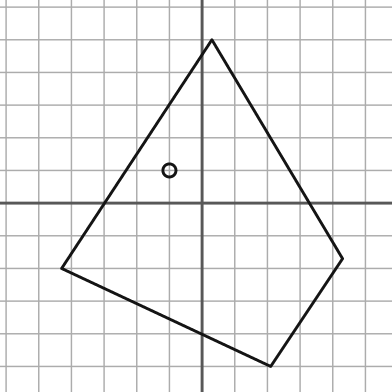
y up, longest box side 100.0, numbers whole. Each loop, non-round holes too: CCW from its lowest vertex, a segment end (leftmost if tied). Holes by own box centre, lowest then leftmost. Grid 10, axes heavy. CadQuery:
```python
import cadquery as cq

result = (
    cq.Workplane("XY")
    .moveTo(21.0, -50.0)
    .lineTo(43.0, -17.0)
    .lineTo(3.0, 50.0)
    .lineTo(-43.0, -20.0)
    .close()
    .moveTo(-10.0, 10.0)
    .circle(2.0)
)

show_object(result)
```